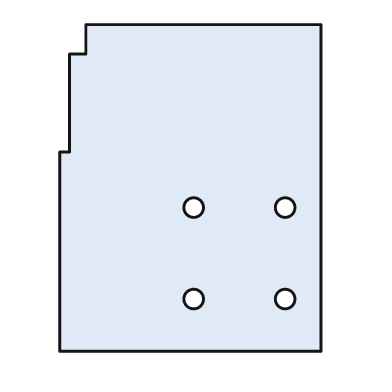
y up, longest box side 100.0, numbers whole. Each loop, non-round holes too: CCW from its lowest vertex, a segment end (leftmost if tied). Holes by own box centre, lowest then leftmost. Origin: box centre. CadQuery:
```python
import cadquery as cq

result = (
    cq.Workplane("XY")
    .moveTo(-40.0, -50.0)
    .lineTo(40.0, -50.0)
    .lineTo(40.0, 50.0)
    .lineTo(-32.0, 50.0)
    .lineTo(-32.0, 41.0)
    .lineTo(-37.0, 41.0)
    .lineTo(-37.0, 11.0)
    .lineTo(-40.0, 11.0)
    .close()
    .moveTo(1.0, -34.0)
    .circle(3.0)
    .moveTo(29.0, -34.0)
    .circle(3.0)
    .moveTo(1.0, -6.0)
    .circle(3.0)
    .moveTo(29.0, -6.0)
    .circle(3.0)
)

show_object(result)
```